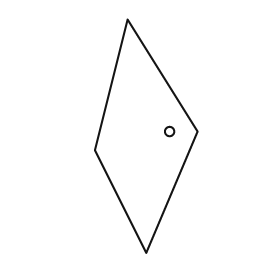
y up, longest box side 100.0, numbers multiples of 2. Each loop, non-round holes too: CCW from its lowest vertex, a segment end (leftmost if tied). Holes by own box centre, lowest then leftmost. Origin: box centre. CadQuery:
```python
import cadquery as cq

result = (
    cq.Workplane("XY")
    .moveTo(0.0, -50.0)
    .lineTo(22.0, 2.0)
    .lineTo(-8.0, 50.0)
    .lineTo(-22.0, -6.0)
    .close()
    .moveTo(10.0, 2.0)
    .circle(2.0)
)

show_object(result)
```